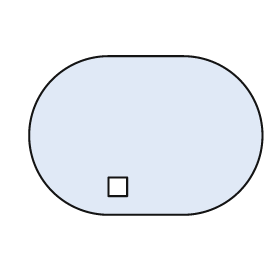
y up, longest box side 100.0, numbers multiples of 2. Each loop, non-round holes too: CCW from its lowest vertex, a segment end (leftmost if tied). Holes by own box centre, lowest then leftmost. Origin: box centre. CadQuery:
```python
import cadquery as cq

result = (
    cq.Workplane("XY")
    .moveTo(-16.0, -34.0)
    .lineTo(16.0, -34.0)
    .threePointArc((50.0, 0.0), (16.0, 34.0))
    .lineTo(-16.0, 34.0)
    .threePointArc((-50.0, 0.0), (-16.0, -34.0))
    .close()
    .moveTo(-16.0, -26.0)
    .lineTo(-8.0, -26.0)
    .lineTo(-8.0, -18.0)
    .lineTo(-16.0, -18.0)
    .close()
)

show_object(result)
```